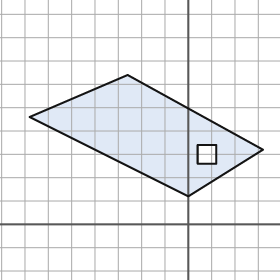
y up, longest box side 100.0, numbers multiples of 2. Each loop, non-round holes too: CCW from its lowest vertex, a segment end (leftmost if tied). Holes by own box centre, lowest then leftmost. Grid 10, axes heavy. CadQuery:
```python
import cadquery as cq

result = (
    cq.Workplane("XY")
    .moveTo(0.0, 12.0)
    .lineTo(32.0, 32.0)
    .lineTo(-26.0, 64.0)
    .lineTo(-68.0, 46.0)
    .close()
    .moveTo(4.0, 26.0)
    .lineTo(12.0, 26.0)
    .lineTo(12.0, 34.0)
    .lineTo(4.0, 34.0)
    .close()
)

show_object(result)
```